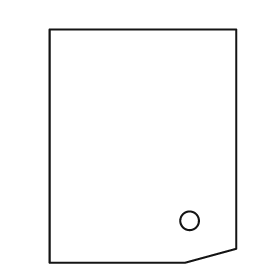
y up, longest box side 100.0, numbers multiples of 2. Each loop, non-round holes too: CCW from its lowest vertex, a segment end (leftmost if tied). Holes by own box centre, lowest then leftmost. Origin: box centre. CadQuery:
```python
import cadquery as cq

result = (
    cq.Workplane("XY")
    .moveTo(-40.0, -50.0)
    .lineTo(18.0, -50.0)
    .lineTo(40.0, -44.0)
    .lineTo(40.0, 50.0)
    .lineTo(-40.0, 50.0)
    .close()
    .moveTo(20.0, -32.0)
    .circle(4.0)
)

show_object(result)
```